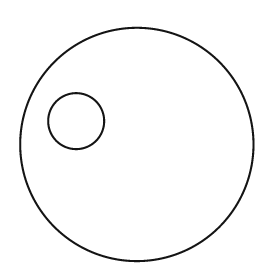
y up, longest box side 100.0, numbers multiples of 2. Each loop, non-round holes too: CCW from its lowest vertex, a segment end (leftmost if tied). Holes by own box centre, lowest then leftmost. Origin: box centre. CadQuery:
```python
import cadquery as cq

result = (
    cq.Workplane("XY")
    .moveTo(0.0, 0.0)
    .circle(50.0)
    .moveTo(-26.0, 10.0)
    .circle(12.0)
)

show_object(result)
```